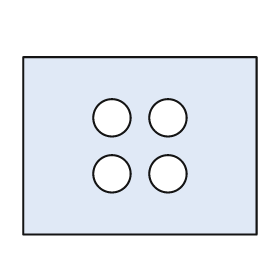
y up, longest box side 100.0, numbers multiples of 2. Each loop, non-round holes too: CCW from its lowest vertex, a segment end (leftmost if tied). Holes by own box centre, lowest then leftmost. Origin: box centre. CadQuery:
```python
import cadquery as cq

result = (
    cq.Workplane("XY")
    .moveTo(-50.0, -38.0)
    .lineTo(50.0, -38.0)
    .lineTo(50.0, 38.0)
    .lineTo(-50.0, 38.0)
    .close()
    .moveTo(-12.0, -12.0)
    .circle(8.0)
    .moveTo(12.0, -12.0)
    .circle(8.0)
    .moveTo(-12.0, 12.0)
    .circle(8.0)
    .moveTo(12.0, 12.0)
    .circle(8.0)
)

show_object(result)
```